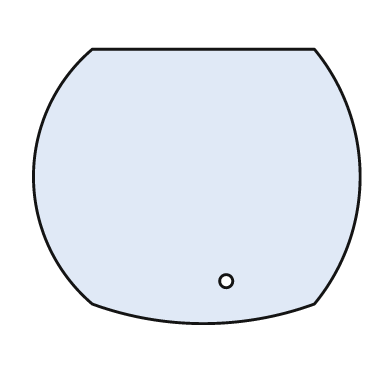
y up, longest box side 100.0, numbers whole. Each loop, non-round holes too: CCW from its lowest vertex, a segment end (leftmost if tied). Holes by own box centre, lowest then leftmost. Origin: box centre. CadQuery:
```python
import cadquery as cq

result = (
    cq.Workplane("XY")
    .moveTo(-32.0, -36.0)
    .threePointArc((2.0, -42.0), (36.0, -36.0))
    .threePointArc((50.0, 3.0), (36.0, 42.0))
    .lineTo(-32.0, 42.0)
    .threePointArc((-50.0, 3.0), (-32.0, -36.0))
    .close()
    .moveTo(9.0, -29.0)
    .circle(2.0)
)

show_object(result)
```